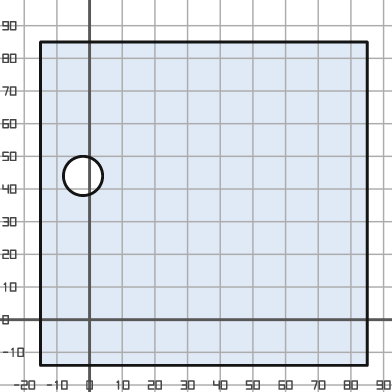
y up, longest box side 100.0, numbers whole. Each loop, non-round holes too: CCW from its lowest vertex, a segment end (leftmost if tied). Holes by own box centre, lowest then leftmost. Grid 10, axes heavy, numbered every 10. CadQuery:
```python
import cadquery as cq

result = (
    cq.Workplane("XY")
    .moveTo(-15.0, -14.0)
    .lineTo(85.0, -14.0)
    .lineTo(85.0, 85.0)
    .lineTo(-15.0, 85.0)
    .close()
    .moveTo(-2.0, 44.0)
    .circle(6.0)
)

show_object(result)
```